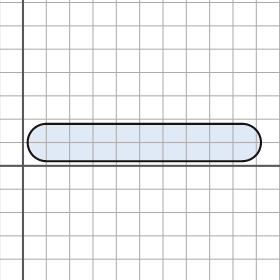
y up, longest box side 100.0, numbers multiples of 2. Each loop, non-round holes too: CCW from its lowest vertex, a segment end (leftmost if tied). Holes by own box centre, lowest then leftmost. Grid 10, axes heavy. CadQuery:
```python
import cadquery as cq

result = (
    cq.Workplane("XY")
    .moveTo(10.0, 2.0)
    .lineTo(94.0, 2.0)
    .threePointArc((102.0, 10.0), (94.0, 18.0))
    .lineTo(10.0, 18.0)
    .threePointArc((2.0, 10.0), (10.0, 2.0))
    .close()
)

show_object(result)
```